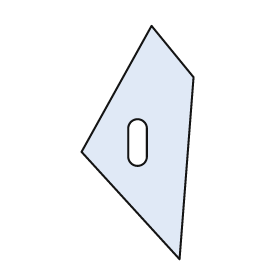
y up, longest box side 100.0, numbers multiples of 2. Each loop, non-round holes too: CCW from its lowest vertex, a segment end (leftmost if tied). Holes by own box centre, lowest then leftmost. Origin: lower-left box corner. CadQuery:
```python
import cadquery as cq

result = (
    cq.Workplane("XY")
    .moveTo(42.0, 0.0)
    .lineTo(48.0, 78.0)
    .lineTo(30.0, 100.0)
    .lineTo(0.0, 46.0)
    .close()
    .moveTo(20.0, 44.0)
    .threePointArc((24.0, 40.0), (28.0, 44.0))
    .lineTo(28.0, 56.0)
    .threePointArc((24.0, 60.0), (20.0, 56.0))
    .close()
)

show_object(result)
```